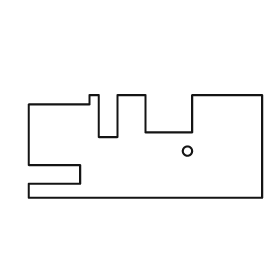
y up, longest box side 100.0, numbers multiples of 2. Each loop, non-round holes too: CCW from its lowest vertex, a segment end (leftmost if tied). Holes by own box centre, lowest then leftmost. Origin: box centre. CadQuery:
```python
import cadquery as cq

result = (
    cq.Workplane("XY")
    .moveTo(-50.0, -22.0)
    .lineTo(50.0, -22.0)
    .lineTo(50.0, 22.0)
    .lineTo(20.0, 22.0)
    .lineTo(20.0, 6.0)
    .lineTo(0.0, 6.0)
    .lineTo(0.0, 22.0)
    .lineTo(-12.0, 22.0)
    .lineTo(-12.0, 4.0)
    .lineTo(-20.0, 4.0)
    .lineTo(-20.0, 22.0)
    .lineTo(-24.0, 22.0)
    .lineTo(-24.0, 18.0)
    .lineTo(-50.0, 18.0)
    .lineTo(-50.0, -8.0)
    .lineTo(-28.0, -8.0)
    .lineTo(-28.0, -16.0)
    .lineTo(-50.0, -16.0)
    .close()
    .moveTo(18.0, -2.0)
    .circle(2.0)
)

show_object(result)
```